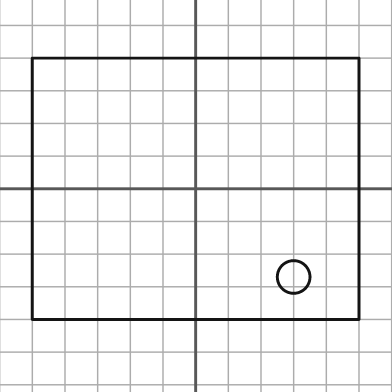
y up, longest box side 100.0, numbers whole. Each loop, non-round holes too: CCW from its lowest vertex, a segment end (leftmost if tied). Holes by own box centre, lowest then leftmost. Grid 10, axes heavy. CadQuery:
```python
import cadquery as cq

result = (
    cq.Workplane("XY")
    .moveTo(-50.0, -40.0)
    .lineTo(50.0, -40.0)
    .lineTo(50.0, 40.0)
    .lineTo(-50.0, 40.0)
    .close()
    .moveTo(30.0, -27.0)
    .circle(5.0)
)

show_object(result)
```